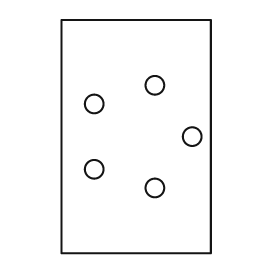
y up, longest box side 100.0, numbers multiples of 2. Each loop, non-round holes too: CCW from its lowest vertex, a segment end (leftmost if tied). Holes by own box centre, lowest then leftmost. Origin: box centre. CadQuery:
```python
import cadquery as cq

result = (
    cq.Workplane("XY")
    .moveTo(-32.0, -50.0)
    .lineTo(32.0, -50.0)
    .lineTo(32.0, 50.0)
    .lineTo(-32.0, 50.0)
    .close()
    .moveTo(8.0, -22.0)
    .circle(4.0)
    .moveTo(-18.0, -14.0)
    .circle(4.0)
    .moveTo(24.0, 0.0)
    .circle(4.0)
    .moveTo(-18.0, 14.0)
    .circle(4.0)
    .moveTo(8.0, 22.0)
    .circle(4.0)
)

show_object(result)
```